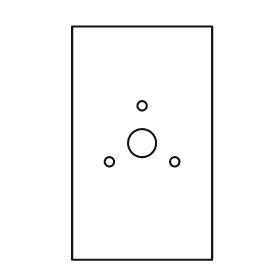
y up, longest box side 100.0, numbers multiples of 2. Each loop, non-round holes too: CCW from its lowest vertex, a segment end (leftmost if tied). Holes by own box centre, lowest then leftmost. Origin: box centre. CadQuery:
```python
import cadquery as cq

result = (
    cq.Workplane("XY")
    .moveTo(-30.0, -50.0)
    .lineTo(30.0, -50.0)
    .lineTo(30.0, 50.0)
    .lineTo(-30.0, 50.0)
    .close()
    .moveTo(-14.0, -8.0)
    .circle(2.0)
    .moveTo(14.0, -8.0)
    .circle(2.0)
    .moveTo(0.0, 0.0)
    .circle(6.0)
    .moveTo(0.0, 16.0)
    .circle(2.0)
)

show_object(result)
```